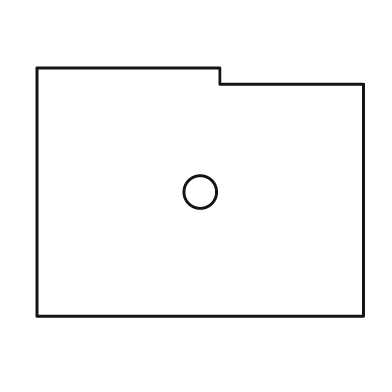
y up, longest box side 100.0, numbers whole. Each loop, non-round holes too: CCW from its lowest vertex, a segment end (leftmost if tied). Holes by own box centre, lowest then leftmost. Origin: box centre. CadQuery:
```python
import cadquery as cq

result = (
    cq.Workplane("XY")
    .moveTo(-50.0, -38.0)
    .lineTo(50.0, -38.0)
    .lineTo(50.0, 33.0)
    .lineTo(6.0, 33.0)
    .lineTo(6.0, 38.0)
    .lineTo(-50.0, 38.0)
    .close()
    .moveTo(0.0, 0.0)
    .circle(5.0)
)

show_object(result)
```